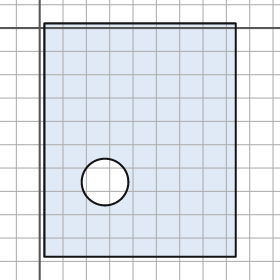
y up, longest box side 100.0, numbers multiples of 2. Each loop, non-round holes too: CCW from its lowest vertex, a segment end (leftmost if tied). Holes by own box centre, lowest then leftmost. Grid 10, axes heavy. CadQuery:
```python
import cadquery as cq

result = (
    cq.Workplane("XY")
    .moveTo(2.0, -98.0)
    .lineTo(84.0, -98.0)
    .lineTo(84.0, 2.0)
    .lineTo(2.0, 2.0)
    .close()
    .moveTo(28.0, -66.0)
    .circle(10.0)
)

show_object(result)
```